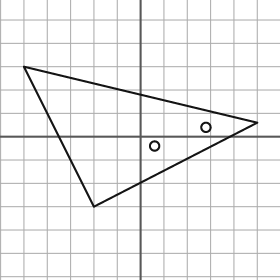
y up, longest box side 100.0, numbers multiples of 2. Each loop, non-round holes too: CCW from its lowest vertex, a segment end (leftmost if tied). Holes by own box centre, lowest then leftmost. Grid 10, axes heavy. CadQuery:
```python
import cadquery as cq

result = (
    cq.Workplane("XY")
    .moveTo(-20.0, -30.0)
    .lineTo(50.0, 6.0)
    .lineTo(-50.0, 30.0)
    .close()
    .moveTo(6.0, -4.0)
    .circle(2.0)
    .moveTo(28.0, 4.0)
    .circle(2.0)
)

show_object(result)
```